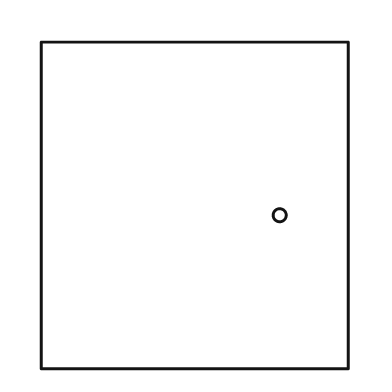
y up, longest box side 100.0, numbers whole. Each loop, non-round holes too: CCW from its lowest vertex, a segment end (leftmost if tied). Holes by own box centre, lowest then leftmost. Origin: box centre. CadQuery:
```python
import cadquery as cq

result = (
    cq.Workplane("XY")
    .moveTo(-47.0, -50.0)
    .lineTo(47.0, -50.0)
    .lineTo(47.0, 50.0)
    .lineTo(-47.0, 50.0)
    .close()
    .moveTo(26.0, -3.0)
    .circle(2.0)
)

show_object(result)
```